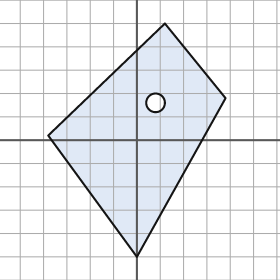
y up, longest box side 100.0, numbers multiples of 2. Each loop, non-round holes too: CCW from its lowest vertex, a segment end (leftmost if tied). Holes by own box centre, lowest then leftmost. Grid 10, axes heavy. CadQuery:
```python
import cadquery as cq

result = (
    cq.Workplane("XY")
    .moveTo(0.0, -50.0)
    .lineTo(38.0, 18.0)
    .lineTo(12.0, 50.0)
    .lineTo(-38.0, 2.0)
    .close()
    .moveTo(8.0, 16.0)
    .circle(4.0)
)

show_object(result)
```